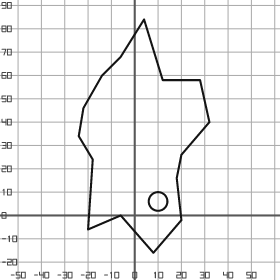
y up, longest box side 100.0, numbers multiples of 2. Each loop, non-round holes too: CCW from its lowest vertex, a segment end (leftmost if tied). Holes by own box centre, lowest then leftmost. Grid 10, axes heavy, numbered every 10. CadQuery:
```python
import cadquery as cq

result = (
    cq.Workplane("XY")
    .moveTo(8.0, -16.0)
    .lineTo(20.0, -2.0)
    .lineTo(18.0, 16.0)
    .lineTo(20.0, 26.0)
    .lineTo(32.0, 40.0)
    .lineTo(28.0, 58.0)
    .lineTo(12.0, 58.0)
    .lineTo(4.0, 84.0)
    .lineTo(-6.0, 68.0)
    .lineTo(-14.0, 60.0)
    .lineTo(-22.0, 46.0)
    .lineTo(-24.0, 34.0)
    .lineTo(-18.0, 24.0)
    .lineTo(-20.0, -6.0)
    .lineTo(-6.0, 0.0)
    .close()
    .moveTo(10.0, 6.0)
    .circle(4.0)
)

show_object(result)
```